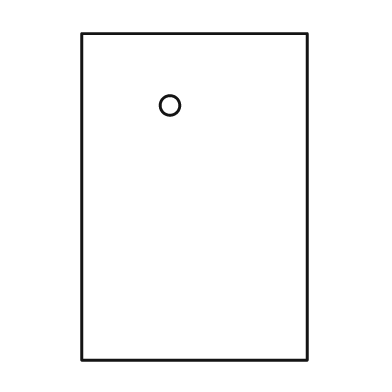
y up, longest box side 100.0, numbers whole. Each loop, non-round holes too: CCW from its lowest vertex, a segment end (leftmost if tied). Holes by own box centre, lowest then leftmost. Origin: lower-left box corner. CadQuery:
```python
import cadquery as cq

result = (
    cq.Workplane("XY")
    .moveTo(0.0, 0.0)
    .lineTo(69.0, 0.0)
    .lineTo(69.0, 100.0)
    .lineTo(0.0, 100.0)
    .close()
    .moveTo(27.0, 78.0)
    .circle(3.0)
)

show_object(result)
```